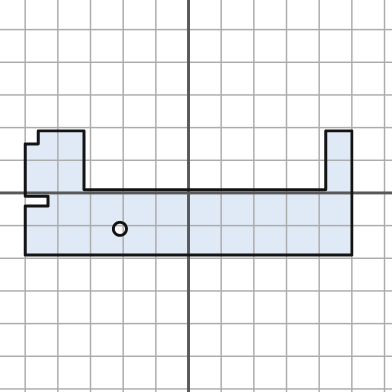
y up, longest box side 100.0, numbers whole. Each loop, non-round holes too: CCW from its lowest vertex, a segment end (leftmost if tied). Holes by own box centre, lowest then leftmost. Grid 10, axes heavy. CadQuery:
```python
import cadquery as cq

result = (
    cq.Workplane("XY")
    .moveTo(-50.0, -19.0)
    .lineTo(50.0, -19.0)
    .lineTo(50.0, 19.0)
    .lineTo(42.0, 19.0)
    .lineTo(42.0, 1.0)
    .lineTo(-32.0, 1.0)
    .lineTo(-32.0, 19.0)
    .lineTo(-46.0, 19.0)
    .lineTo(-46.0, 15.0)
    .lineTo(-50.0, 15.0)
    .lineTo(-50.0, -1.0)
    .lineTo(-43.0, -1.0)
    .lineTo(-43.0, -4.0)
    .lineTo(-50.0, -4.0)
    .close()
    .moveTo(-21.0, -11.0)
    .circle(2.0)
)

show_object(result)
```